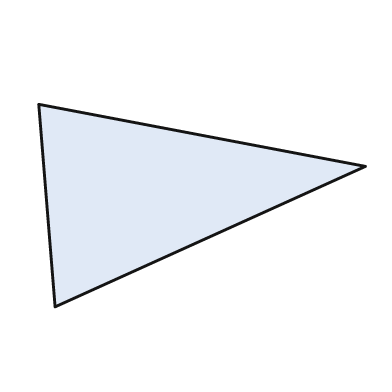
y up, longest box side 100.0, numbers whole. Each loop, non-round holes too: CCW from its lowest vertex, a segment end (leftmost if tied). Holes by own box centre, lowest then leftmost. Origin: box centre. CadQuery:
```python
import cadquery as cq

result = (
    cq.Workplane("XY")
    .moveTo(-45.0, -31.0)
    .lineTo(50.0, 12.0)
    .lineTo(-50.0, 31.0)
    .close()
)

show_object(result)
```